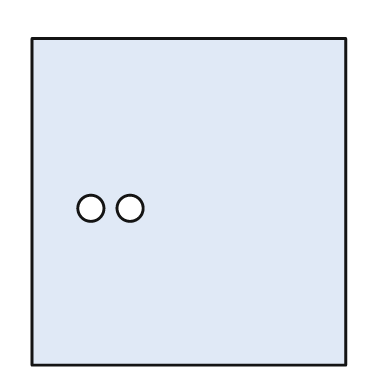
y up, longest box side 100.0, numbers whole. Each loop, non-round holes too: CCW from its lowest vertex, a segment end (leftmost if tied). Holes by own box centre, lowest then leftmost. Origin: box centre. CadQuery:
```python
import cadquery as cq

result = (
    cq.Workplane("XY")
    .moveTo(-48.0, -50.0)
    .lineTo(48.0, -50.0)
    .lineTo(48.0, 50.0)
    .lineTo(-48.0, 50.0)
    .close()
    .moveTo(-30.0, -2.0)
    .circle(4.0)
    .moveTo(-18.0, -2.0)
    .circle(4.0)
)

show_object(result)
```